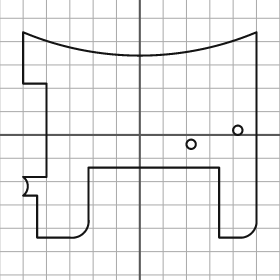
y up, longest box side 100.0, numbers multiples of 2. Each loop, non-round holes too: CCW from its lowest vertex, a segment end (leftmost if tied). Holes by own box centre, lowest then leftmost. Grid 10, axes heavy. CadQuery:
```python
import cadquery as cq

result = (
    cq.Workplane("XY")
    .moveTo(-44.0, -44.0)
    .lineTo(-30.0, -44.0)
    .threePointArc((-24.0, -42.0), (-22.0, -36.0))
    .lineTo(-22.0, -14.0)
    .lineTo(34.0, -14.0)
    .lineTo(34.0, -44.0)
    .lineTo(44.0, -44.0)
    .threePointArc((48.0, -42.0), (50.0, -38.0))
    .lineTo(50.0, 44.0)
    .threePointArc((0.0, 34.0), (-50.0, 44.0))
    .lineTo(-50.0, 22.0)
    .lineTo(-40.0, 22.0)
    .lineTo(-40.0, -18.0)
    .lineTo(-50.0, -18.0)
    .threePointArc((-48.0, -22.0), (-50.0, -26.0))
    .lineTo(-44.0, -26.0)
    .close()
    .moveTo(22.0, -4.0)
    .circle(2.0)
    .moveTo(42.0, 2.0)
    .circle(2.0)
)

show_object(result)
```